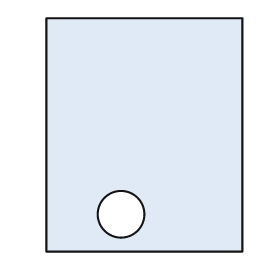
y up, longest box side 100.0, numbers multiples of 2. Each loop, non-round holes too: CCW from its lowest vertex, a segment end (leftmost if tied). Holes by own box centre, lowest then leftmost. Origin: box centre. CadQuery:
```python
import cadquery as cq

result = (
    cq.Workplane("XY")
    .moveTo(-42.0, -50.0)
    .lineTo(42.0, -50.0)
    .lineTo(42.0, 50.0)
    .lineTo(-42.0, 50.0)
    .close()
    .moveTo(-10.0, -34.0)
    .circle(10.0)
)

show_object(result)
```